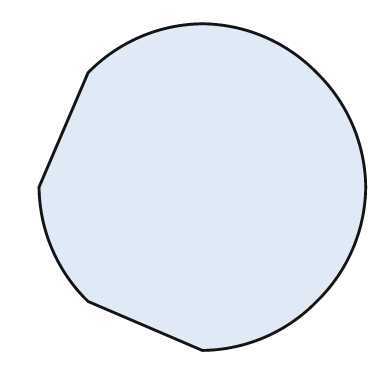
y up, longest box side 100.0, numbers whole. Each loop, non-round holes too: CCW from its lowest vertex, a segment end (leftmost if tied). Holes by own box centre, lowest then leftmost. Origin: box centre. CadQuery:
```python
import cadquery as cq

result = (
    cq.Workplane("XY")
    .moveTo(0.0, -50.0)
    .threePointArc((19.0, -46.0), (35.0, -35.0))
    .threePointArc((46.0, -19.0), (50.0, 0.0))
    .threePointArc((46.0, 19.0), (35.0, 35.0))
    .threePointArc((19.0, 46.0), (0.0, 50.0))
    .threePointArc((-19.0, 46.0), (-35.0, 35.0))
    .lineTo(-50.0, 0.0)
    .threePointArc((-46.0, -19.0), (-35.0, -35.0))
    .close()
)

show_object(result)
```